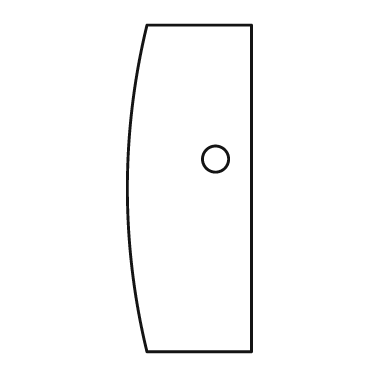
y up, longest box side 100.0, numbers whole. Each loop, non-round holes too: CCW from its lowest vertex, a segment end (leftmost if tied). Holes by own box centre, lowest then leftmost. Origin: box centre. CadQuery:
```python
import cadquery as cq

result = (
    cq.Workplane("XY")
    .moveTo(-13.0, -50.0)
    .lineTo(19.0, -50.0)
    .lineTo(19.0, 50.0)
    .lineTo(-13.0, 50.0)
    .threePointArc((-19.0, 0.0), (-13.0, -50.0))
    .close()
    .moveTo(8.0, 9.0)
    .circle(4.0)
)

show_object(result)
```